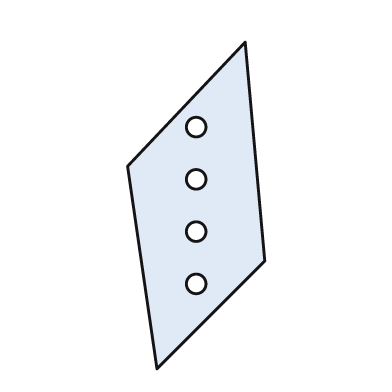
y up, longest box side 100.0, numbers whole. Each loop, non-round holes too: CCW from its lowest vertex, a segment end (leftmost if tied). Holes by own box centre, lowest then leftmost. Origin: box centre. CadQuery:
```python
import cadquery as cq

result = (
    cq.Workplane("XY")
    .moveTo(-12.0, -50.0)
    .lineTo(21.0, -17.0)
    .lineTo(15.0, 50.0)
    .lineTo(-21.0, 12.0)
    .close()
    .moveTo(0.0, -24.0)
    .circle(3.0)
    .moveTo(0.0, -8.0)
    .circle(3.0)
    .moveTo(0.0, 8.0)
    .circle(3.0)
    .moveTo(0.0, 24.0)
    .circle(3.0)
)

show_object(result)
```